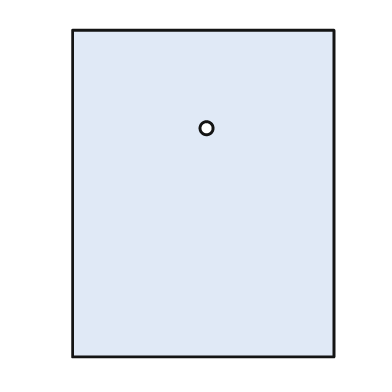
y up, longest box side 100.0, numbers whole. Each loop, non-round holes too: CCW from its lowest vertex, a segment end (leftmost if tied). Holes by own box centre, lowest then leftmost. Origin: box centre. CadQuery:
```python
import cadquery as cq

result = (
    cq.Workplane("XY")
    .moveTo(-40.0, -50.0)
    .lineTo(40.0, -50.0)
    .lineTo(40.0, 50.0)
    .lineTo(-40.0, 50.0)
    .close()
    .moveTo(1.0, 20.0)
    .circle(2.0)
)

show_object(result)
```